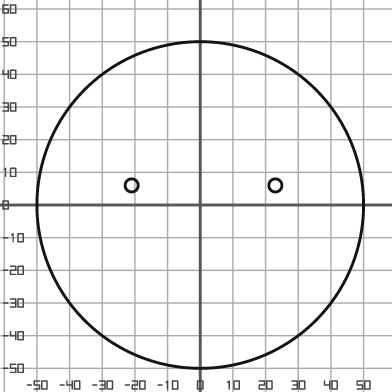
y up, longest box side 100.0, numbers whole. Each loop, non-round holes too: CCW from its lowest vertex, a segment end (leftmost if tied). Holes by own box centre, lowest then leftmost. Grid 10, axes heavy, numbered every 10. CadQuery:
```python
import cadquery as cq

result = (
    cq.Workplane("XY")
    .moveTo(0.0, 0.0)
    .circle(50.0)
    .moveTo(-21.0, 6.0)
    .circle(2.0)
    .moveTo(23.0, 6.0)
    .circle(2.0)
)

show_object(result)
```